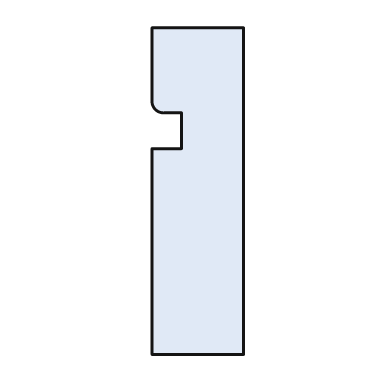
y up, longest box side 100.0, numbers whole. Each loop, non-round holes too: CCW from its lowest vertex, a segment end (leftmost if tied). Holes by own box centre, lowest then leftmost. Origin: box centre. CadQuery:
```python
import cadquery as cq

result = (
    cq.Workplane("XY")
    .moveTo(-14.0, -50.0)
    .lineTo(14.0, -50.0)
    .lineTo(14.0, 50.0)
    .lineTo(-14.0, 50.0)
    .lineTo(-14.0, 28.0)
    .threePointArc((-13.0, 25.0), (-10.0, 24.0))
    .lineTo(-5.0, 24.0)
    .lineTo(-5.0, 13.0)
    .lineTo(-14.0, 13.0)
    .close()
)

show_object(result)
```